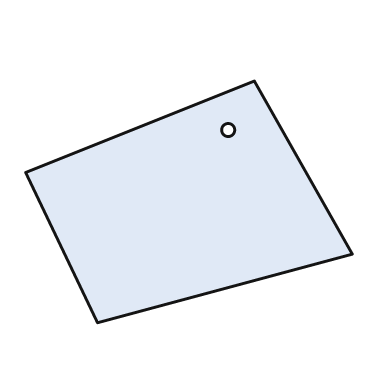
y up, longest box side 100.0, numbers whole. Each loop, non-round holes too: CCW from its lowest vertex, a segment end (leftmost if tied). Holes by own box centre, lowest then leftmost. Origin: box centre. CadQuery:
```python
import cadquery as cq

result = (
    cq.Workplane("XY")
    .moveTo(-28.0, -37.0)
    .lineTo(50.0, -16.0)
    .lineTo(20.0, 37.0)
    .lineTo(-50.0, 9.0)
    .close()
    .moveTo(12.0, 22.0)
    .circle(2.0)
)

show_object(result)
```